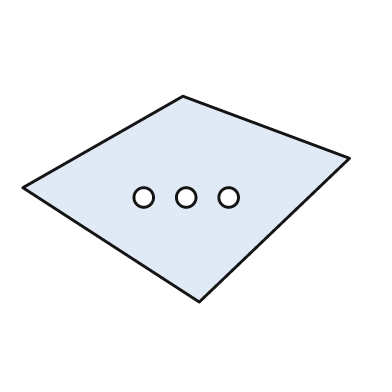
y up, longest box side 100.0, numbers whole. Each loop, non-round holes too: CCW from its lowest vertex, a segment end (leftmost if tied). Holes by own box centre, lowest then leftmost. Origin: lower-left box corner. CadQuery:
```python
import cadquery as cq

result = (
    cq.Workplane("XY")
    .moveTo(54.0, 0.0)
    .lineTo(100.0, 44.0)
    .lineTo(49.0, 63.0)
    .lineTo(0.0, 35.0)
    .close()
    .moveTo(37.0, 32.0)
    .circle(3.0)
    .moveTo(50.0, 32.0)
    .circle(3.0)
    .moveTo(63.0, 32.0)
    .circle(3.0)
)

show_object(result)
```